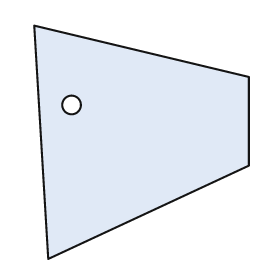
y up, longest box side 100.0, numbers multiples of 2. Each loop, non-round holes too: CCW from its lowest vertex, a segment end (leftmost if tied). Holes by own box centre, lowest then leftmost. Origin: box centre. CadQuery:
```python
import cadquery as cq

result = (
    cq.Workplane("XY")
    .moveTo(-40.0, -50.0)
    .lineTo(46.0, -10.0)
    .lineTo(46.0, 28.0)
    .lineTo(-46.0, 50.0)
    .close()
    .moveTo(-30.0, 16.0)
    .circle(4.0)
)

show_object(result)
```